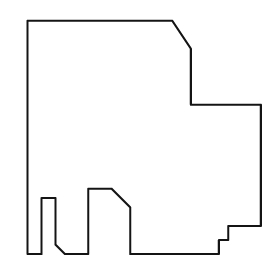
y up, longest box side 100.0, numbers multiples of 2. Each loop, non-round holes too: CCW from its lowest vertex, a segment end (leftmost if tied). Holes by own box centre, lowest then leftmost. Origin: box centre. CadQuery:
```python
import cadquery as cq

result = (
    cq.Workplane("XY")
    .moveTo(-50.0, -50.0)
    .lineTo(-44.0, -50.0)
    .lineTo(-44.0, -26.0)
    .lineTo(-38.0, -26.0)
    .lineTo(-38.0, -46.0)
    .lineTo(-34.0, -50.0)
    .lineTo(-24.0, -50.0)
    .lineTo(-24.0, -22.0)
    .lineTo(-14.0, -22.0)
    .lineTo(-6.0, -30.0)
    .lineTo(-6.0, -50.0)
    .lineTo(32.0, -50.0)
    .lineTo(32.0, -44.0)
    .lineTo(36.0, -44.0)
    .lineTo(36.0, -38.0)
    .lineTo(50.0, -38.0)
    .lineTo(50.0, 14.0)
    .lineTo(20.0, 14.0)
    .lineTo(20.0, 38.0)
    .lineTo(12.0, 50.0)
    .lineTo(-50.0, 50.0)
    .close()
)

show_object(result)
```